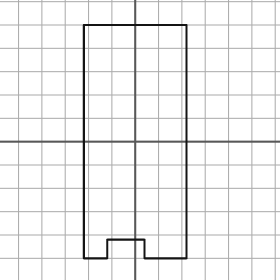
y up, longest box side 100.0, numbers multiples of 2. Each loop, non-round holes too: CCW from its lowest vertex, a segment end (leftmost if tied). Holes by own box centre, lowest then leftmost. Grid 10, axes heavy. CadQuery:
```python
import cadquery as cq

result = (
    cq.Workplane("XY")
    .moveTo(-22.0, -50.0)
    .lineTo(-12.0, -50.0)
    .lineTo(-12.0, -42.0)
    .lineTo(4.0, -42.0)
    .lineTo(4.0, -50.0)
    .lineTo(22.0, -50.0)
    .lineTo(22.0, 50.0)
    .lineTo(-22.0, 50.0)
    .close()
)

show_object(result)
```